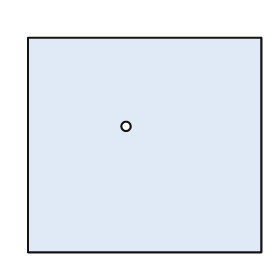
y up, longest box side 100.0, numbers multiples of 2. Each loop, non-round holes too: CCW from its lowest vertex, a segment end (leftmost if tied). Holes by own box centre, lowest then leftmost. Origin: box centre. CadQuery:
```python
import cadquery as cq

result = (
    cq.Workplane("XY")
    .moveTo(-50.0, -46.0)
    .lineTo(50.0, -46.0)
    .lineTo(50.0, 46.0)
    .lineTo(-50.0, 46.0)
    .close()
    .moveTo(-8.0, 8.0)
    .circle(2.0)
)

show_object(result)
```